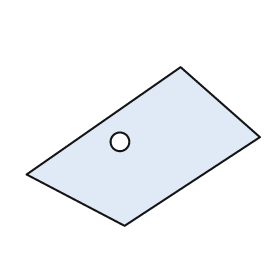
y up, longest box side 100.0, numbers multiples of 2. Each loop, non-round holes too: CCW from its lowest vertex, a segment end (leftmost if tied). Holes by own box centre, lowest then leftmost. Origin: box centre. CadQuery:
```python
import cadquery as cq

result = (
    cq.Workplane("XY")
    .moveTo(-8.0, -34.0)
    .lineTo(50.0, 4.0)
    .lineTo(16.0, 34.0)
    .lineTo(-50.0, -12.0)
    .close()
    .moveTo(-10.0, 2.0)
    .circle(4.0)
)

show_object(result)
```